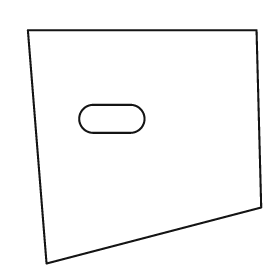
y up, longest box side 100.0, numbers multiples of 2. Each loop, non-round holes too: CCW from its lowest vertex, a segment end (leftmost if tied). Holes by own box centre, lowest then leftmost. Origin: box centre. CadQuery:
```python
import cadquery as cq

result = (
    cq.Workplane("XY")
    .moveTo(-42.0, -50.0)
    .lineTo(50.0, -26.0)
    .lineTo(48.0, 50.0)
    .lineTo(-50.0, 50.0)
    .close()
    .moveTo(-22.0, 6.0)
    .lineTo(-6.0, 6.0)
    .threePointArc((0.0, 12.0), (-6.0, 18.0))
    .lineTo(-22.0, 18.0)
    .threePointArc((-28.0, 12.0), (-22.0, 6.0))
    .close()
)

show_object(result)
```